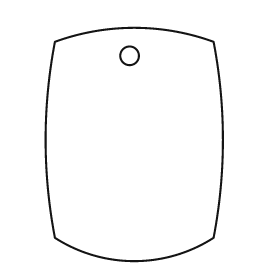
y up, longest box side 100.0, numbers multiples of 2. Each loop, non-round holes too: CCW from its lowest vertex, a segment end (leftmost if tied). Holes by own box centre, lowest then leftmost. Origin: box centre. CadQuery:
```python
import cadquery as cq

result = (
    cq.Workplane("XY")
    .moveTo(-34.0, -40.0)
    .threePointArc((0.0, -50.0), (34.0, -40.0))
    .threePointArc((38.0, 2.0), (34.0, 44.0))
    .threePointArc((0.0, 50.0), (-34.0, 44.0))
    .threePointArc((-38.0, 2.0), (-34.0, -40.0))
    .close()
    .moveTo(-2.0, 38.0)
    .circle(4.0)
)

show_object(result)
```